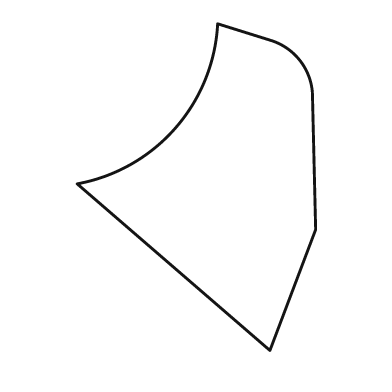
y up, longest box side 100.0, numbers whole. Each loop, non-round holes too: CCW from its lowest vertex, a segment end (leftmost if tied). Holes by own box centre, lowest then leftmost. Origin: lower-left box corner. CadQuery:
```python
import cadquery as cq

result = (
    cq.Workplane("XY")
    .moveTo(59.0, 0.0)
    .lineTo(73.0, 37.0)
    .lineTo(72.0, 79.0)
    .threePointArc((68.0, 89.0), (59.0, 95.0))
    .lineTo(43.0, 100.0)
    .threePointArc((30.0, 68.0), (0.0, 51.0))
    .close()
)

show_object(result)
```